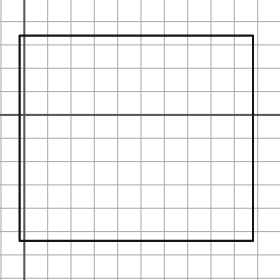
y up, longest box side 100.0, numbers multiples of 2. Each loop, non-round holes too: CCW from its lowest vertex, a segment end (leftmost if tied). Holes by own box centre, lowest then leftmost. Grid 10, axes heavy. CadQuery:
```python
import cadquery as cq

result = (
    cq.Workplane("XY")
    .moveTo(-2.0, -54.0)
    .lineTo(98.0, -54.0)
    .lineTo(98.0, 34.0)
    .lineTo(-2.0, 34.0)
    .close()
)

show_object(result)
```